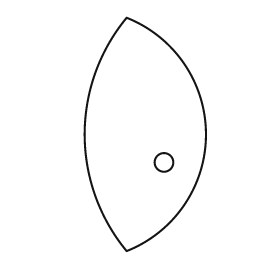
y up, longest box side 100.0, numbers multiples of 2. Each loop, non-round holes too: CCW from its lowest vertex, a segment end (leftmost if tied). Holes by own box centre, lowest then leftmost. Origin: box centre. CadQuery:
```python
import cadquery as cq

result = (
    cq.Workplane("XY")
    .moveTo(-8.0, -50.0)
    .threePointArc((26.0, 0.0), (-8.0, 50.0))
    .threePointArc((-26.0, 0.0), (-8.0, -50.0))
    .close()
    .moveTo(8.0, -12.0)
    .circle(4.0)
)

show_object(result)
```